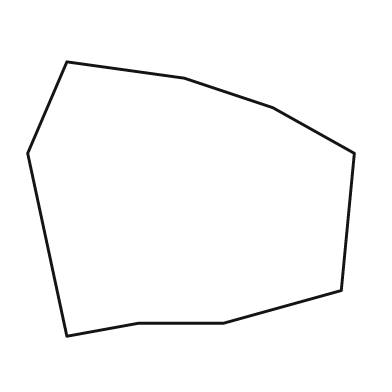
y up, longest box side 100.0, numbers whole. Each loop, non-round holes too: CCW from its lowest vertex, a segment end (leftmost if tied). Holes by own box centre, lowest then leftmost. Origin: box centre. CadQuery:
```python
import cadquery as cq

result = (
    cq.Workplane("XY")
    .moveTo(-38.0, -42.0)
    .lineTo(-16.0, -38.0)
    .lineTo(10.0, -38.0)
    .lineTo(46.0, -28.0)
    .lineTo(50.0, 14.0)
    .lineTo(25.0, 28.0)
    .lineTo(-2.0, 37.0)
    .lineTo(-38.0, 42.0)
    .lineTo(-50.0, 14.0)
    .close()
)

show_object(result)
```